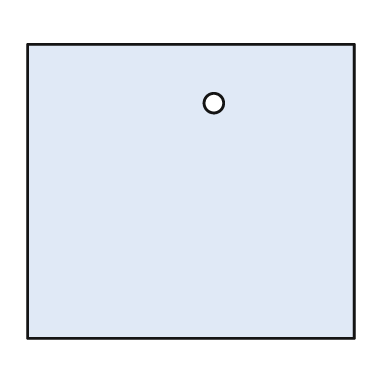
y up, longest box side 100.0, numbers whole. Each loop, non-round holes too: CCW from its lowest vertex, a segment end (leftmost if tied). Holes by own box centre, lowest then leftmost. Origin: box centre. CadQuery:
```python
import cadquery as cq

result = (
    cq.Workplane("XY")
    .moveTo(-50.0, -45.0)
    .lineTo(50.0, -45.0)
    .lineTo(50.0, 45.0)
    .lineTo(-50.0, 45.0)
    .close()
    .moveTo(7.0, 27.0)
    .circle(3.0)
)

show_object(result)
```